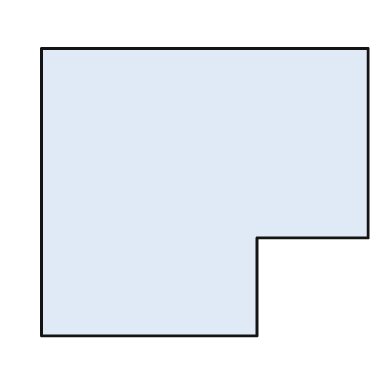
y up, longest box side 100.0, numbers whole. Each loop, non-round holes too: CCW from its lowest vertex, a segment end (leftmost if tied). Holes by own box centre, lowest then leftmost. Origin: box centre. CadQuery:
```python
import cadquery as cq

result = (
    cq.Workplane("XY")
    .moveTo(-50.0, -44.0)
    .lineTo(16.0, -44.0)
    .lineTo(16.0, -14.0)
    .lineTo(50.0, -14.0)
    .lineTo(50.0, 44.0)
    .lineTo(-50.0, 44.0)
    .close()
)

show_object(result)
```